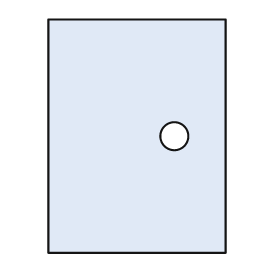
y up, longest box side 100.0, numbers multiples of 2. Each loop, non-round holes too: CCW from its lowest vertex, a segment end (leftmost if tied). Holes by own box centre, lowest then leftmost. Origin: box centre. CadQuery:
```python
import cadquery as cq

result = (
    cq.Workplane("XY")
    .moveTo(-38.0, -50.0)
    .lineTo(38.0, -50.0)
    .lineTo(38.0, 50.0)
    .lineTo(-38.0, 50.0)
    .close()
    .moveTo(16.0, 0.0)
    .circle(6.0)
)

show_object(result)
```